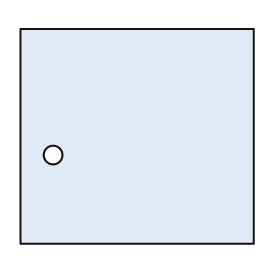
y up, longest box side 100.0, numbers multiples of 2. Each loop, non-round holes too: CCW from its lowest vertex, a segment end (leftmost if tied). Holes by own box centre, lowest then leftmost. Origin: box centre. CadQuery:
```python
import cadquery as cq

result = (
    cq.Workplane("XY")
    .moveTo(-50.0, -46.0)
    .lineTo(50.0, -46.0)
    .lineTo(50.0, 46.0)
    .lineTo(-50.0, 46.0)
    .close()
    .moveTo(-36.0, -8.0)
    .circle(4.0)
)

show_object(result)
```